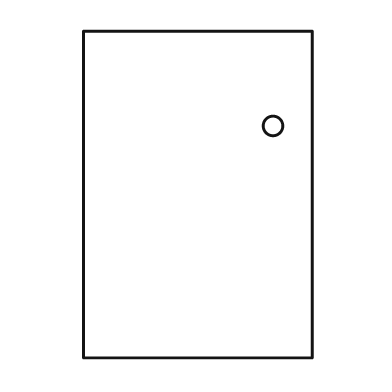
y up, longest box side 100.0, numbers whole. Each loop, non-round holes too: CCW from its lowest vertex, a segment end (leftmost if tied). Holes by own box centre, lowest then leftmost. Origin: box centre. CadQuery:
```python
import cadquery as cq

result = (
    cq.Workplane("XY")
    .moveTo(-35.0, -50.0)
    .lineTo(35.0, -50.0)
    .lineTo(35.0, 50.0)
    .lineTo(-35.0, 50.0)
    .close()
    .moveTo(23.0, 21.0)
    .circle(3.0)
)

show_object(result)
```